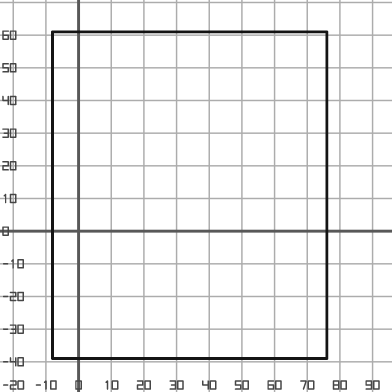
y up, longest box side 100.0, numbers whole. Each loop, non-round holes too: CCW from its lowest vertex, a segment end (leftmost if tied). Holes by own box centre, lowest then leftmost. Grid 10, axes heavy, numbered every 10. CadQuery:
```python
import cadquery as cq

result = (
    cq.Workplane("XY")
    .moveTo(-8.0, -39.0)
    .lineTo(76.0, -39.0)
    .lineTo(76.0, 61.0)
    .lineTo(-8.0, 61.0)
    .close()
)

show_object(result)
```